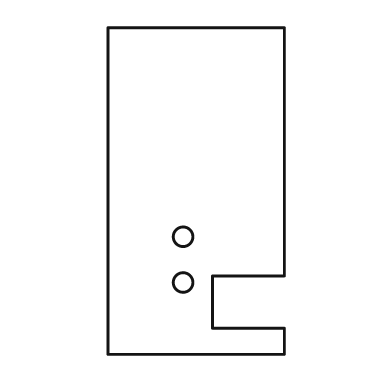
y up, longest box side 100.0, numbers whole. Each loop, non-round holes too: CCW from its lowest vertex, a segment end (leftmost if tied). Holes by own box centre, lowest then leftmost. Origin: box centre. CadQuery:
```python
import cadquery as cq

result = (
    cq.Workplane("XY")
    .moveTo(-27.0, -50.0)
    .lineTo(27.0, -50.0)
    .lineTo(27.0, -42.0)
    .lineTo(5.0, -42.0)
    .lineTo(5.0, -26.0)
    .lineTo(27.0, -26.0)
    .lineTo(27.0, 50.0)
    .lineTo(-27.0, 50.0)
    .close()
    .moveTo(-4.0, -28.0)
    .circle(3.0)
    .moveTo(-4.0, -14.0)
    .circle(3.0)
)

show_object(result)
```